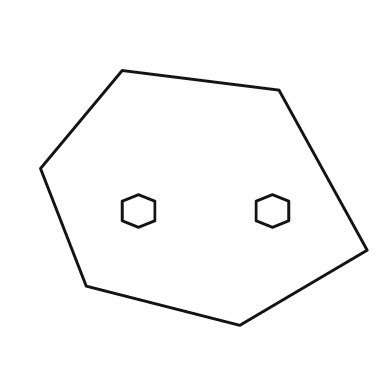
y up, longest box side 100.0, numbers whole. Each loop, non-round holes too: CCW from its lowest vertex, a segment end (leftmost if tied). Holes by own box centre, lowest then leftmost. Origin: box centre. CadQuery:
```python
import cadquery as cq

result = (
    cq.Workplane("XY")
    .moveTo(11.0, -39.0)
    .lineTo(50.0, -16.0)
    .lineTo(23.0, 33.0)
    .lineTo(-25.0, 39.0)
    .lineTo(-50.0, 9.0)
    .lineTo(-36.0, -27.0)
    .close()
    .moveTo(-20.0, -9.0)
    .lineTo(-15.0, -7.0)
    .lineTo(-15.0, -1.0)
    .lineTo(-20.0, 1.0)
    .lineTo(-25.0, -1.0)
    .lineTo(-25.0, -7.0)
    .close()
    .moveTo(21.0, -9.0)
    .lineTo(26.0, -7.0)
    .lineTo(26.0, -1.0)
    .lineTo(21.0, 1.0)
    .lineTo(16.0, -1.0)
    .lineTo(16.0, -7.0)
    .close()
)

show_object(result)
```